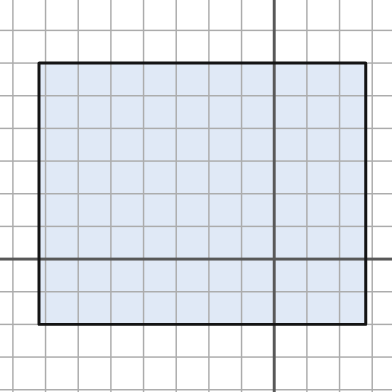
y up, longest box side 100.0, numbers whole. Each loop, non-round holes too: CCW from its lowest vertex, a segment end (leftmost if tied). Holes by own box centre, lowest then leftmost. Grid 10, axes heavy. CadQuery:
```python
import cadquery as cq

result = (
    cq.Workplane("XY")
    .moveTo(-72.0, -20.0)
    .lineTo(28.0, -20.0)
    .lineTo(28.0, 60.0)
    .lineTo(-72.0, 60.0)
    .close()
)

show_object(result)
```